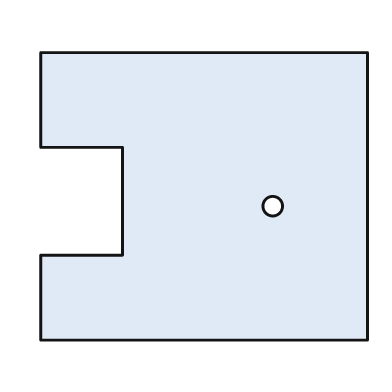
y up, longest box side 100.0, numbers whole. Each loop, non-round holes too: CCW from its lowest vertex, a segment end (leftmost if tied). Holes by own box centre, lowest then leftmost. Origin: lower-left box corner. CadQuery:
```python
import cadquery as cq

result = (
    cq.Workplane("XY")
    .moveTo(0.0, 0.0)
    .lineTo(100.0, 0.0)
    .lineTo(100.0, 88.0)
    .lineTo(0.0, 88.0)
    .lineTo(0.0, 59.0)
    .lineTo(25.0, 59.0)
    .lineTo(25.0, 26.0)
    .lineTo(0.0, 26.0)
    .close()
    .moveTo(71.0, 41.0)
    .circle(3.0)
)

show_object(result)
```